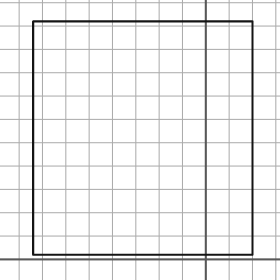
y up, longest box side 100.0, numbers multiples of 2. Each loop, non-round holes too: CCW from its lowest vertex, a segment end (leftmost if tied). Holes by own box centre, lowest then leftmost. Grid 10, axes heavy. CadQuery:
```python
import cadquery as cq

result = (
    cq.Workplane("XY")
    .moveTo(-74.0, 2.0)
    .lineTo(20.0, 2.0)
    .lineTo(20.0, 102.0)
    .lineTo(-74.0, 102.0)
    .close()
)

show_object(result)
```